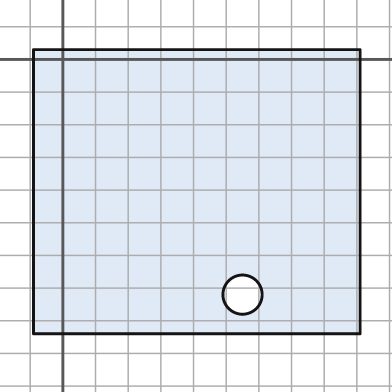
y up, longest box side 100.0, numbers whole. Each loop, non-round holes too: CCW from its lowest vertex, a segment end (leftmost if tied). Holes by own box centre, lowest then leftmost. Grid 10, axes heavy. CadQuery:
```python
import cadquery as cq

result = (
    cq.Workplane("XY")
    .moveTo(-9.0, -84.0)
    .lineTo(91.0, -84.0)
    .lineTo(91.0, 3.0)
    .lineTo(-9.0, 3.0)
    .close()
    .moveTo(55.0, -72.0)
    .circle(6.0)
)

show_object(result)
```